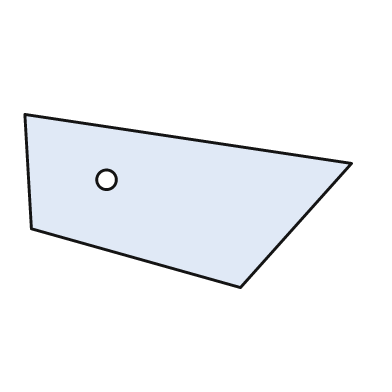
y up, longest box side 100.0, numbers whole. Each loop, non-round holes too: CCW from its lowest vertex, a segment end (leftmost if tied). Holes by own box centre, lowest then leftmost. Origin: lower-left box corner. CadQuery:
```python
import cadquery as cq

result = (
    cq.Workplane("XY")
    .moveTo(66.0, 0.0)
    .lineTo(100.0, 38.0)
    .lineTo(0.0, 53.0)
    .lineTo(2.0, 18.0)
    .close()
    .moveTo(25.0, 33.0)
    .circle(3.0)
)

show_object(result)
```